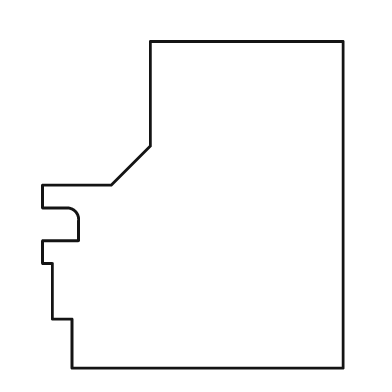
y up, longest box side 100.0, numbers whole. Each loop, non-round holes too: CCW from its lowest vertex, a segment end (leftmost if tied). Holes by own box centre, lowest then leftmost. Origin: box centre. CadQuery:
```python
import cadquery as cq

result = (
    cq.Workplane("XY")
    .moveTo(-37.0, -50.0)
    .lineTo(46.0, -50.0)
    .lineTo(46.0, 50.0)
    .lineTo(-13.0, 50.0)
    .lineTo(-13.0, 18.0)
    .lineTo(-25.0, 6.0)
    .lineTo(-46.0, 6.0)
    .lineTo(-46.0, -1.0)
    .lineTo(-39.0, -1.0)
    .threePointArc((-36.0, -2.0), (-35.0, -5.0))
    .lineTo(-35.0, -11.0)
    .lineTo(-46.0, -11.0)
    .lineTo(-46.0, -18.0)
    .lineTo(-43.0, -18.0)
    .lineTo(-43.0, -35.0)
    .lineTo(-37.0, -35.0)
    .close()
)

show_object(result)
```